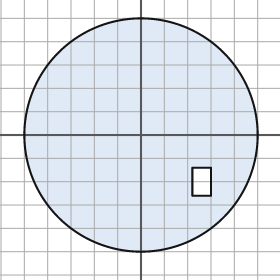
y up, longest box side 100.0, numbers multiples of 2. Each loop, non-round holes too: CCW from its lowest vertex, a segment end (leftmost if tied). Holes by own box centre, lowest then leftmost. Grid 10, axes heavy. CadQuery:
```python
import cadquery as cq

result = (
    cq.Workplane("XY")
    .moveTo(0.0, 0.0)
    .circle(50.0)
    .moveTo(22.0, -26.0)
    .lineTo(30.0, -26.0)
    .lineTo(30.0, -14.0)
    .lineTo(22.0, -14.0)
    .close()
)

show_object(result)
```